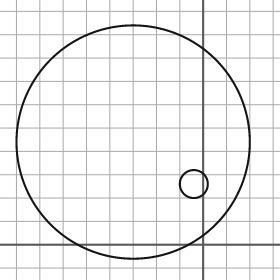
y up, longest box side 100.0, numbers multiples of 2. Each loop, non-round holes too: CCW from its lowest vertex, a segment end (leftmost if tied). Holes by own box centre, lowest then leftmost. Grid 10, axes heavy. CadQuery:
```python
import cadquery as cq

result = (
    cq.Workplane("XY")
    .moveTo(-30.0, 44.0)
    .circle(50.0)
    .moveTo(-4.0, 26.0)
    .circle(6.0)
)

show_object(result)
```